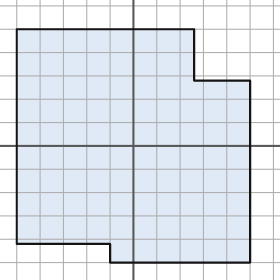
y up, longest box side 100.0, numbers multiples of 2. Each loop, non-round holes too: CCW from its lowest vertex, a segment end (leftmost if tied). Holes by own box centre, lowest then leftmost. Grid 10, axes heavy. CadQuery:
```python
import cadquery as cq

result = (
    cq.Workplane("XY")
    .moveTo(-10.0, -50.0)
    .lineTo(50.0, -50.0)
    .lineTo(50.0, 28.0)
    .lineTo(26.0, 28.0)
    .lineTo(26.0, 50.0)
    .lineTo(-50.0, 50.0)
    .lineTo(-50.0, -42.0)
    .lineTo(-10.0, -42.0)
    .close()
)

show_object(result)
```